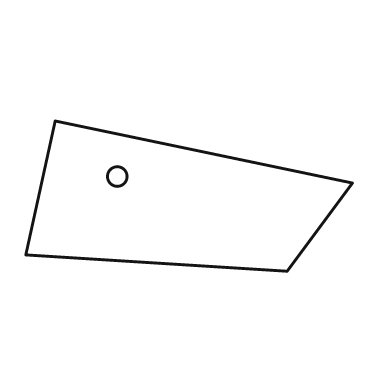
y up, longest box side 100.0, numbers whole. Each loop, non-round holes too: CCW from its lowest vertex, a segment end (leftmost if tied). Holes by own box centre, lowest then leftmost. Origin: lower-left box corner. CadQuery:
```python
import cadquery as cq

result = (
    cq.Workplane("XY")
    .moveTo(80.0, 0.0)
    .lineTo(100.0, 27.0)
    .lineTo(9.0, 46.0)
    .lineTo(0.0, 5.0)
    .close()
    .moveTo(28.0, 29.0)
    .circle(3.0)
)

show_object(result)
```